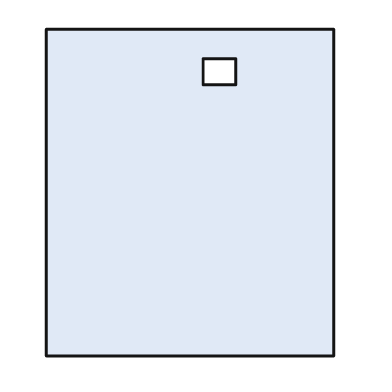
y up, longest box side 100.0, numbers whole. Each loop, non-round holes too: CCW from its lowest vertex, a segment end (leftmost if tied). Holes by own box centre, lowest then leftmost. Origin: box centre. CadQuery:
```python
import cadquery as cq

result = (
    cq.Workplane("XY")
    .moveTo(-44.0, -50.0)
    .lineTo(44.0, -50.0)
    .lineTo(44.0, 50.0)
    .lineTo(-44.0, 50.0)
    .close()
    .moveTo(4.0, 33.0)
    .lineTo(14.0, 33.0)
    .lineTo(14.0, 41.0)
    .lineTo(4.0, 41.0)
    .close()
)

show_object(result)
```